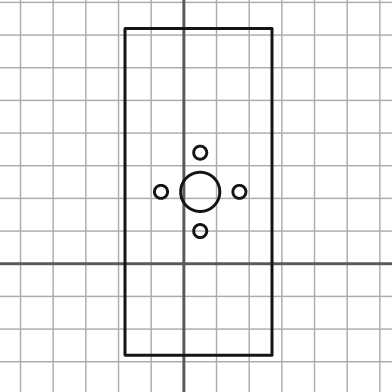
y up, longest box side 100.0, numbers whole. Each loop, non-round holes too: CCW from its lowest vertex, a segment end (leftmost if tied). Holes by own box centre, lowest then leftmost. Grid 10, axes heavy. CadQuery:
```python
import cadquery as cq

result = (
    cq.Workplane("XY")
    .moveTo(-18.0, -28.0)
    .lineTo(27.0, -28.0)
    .lineTo(27.0, 72.0)
    .lineTo(-18.0, 72.0)
    .close()
    .moveTo(5.0, 10.0)
    .circle(2.0)
    .moveTo(-7.0, 22.0)
    .circle(2.0)
    .moveTo(5.0, 22.0)
    .circle(6.0)
    .moveTo(17.0, 22.0)
    .circle(2.0)
    .moveTo(5.0, 34.0)
    .circle(2.0)
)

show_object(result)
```